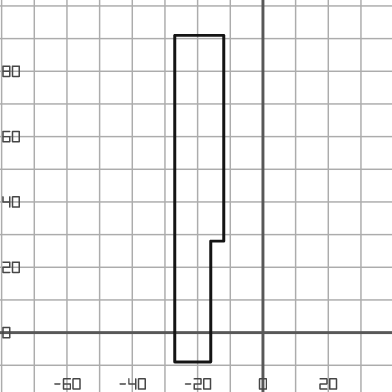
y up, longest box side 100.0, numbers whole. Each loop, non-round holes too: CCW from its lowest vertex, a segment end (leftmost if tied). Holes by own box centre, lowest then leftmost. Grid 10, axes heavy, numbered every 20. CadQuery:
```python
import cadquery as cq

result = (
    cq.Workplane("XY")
    .moveTo(-27.0, -9.0)
    .lineTo(-16.0, -9.0)
    .lineTo(-16.0, 28.0)
    .lineTo(-12.0, 28.0)
    .lineTo(-12.0, 91.0)
    .lineTo(-27.0, 91.0)
    .close()
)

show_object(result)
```